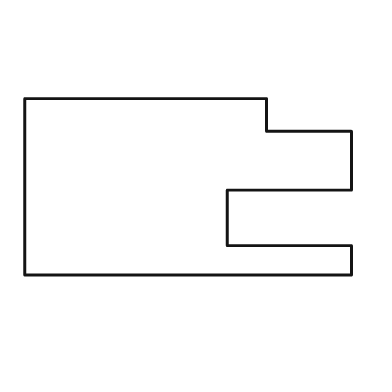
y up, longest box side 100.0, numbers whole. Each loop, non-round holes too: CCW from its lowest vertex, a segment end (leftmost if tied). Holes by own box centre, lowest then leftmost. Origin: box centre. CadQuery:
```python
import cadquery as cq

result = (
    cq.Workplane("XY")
    .moveTo(-50.0, -27.0)
    .lineTo(50.0, -27.0)
    .lineTo(50.0, -18.0)
    .lineTo(12.0, -18.0)
    .lineTo(12.0, -1.0)
    .lineTo(50.0, -1.0)
    .lineTo(50.0, 17.0)
    .lineTo(24.0, 17.0)
    .lineTo(24.0, 27.0)
    .lineTo(-50.0, 27.0)
    .close()
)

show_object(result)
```